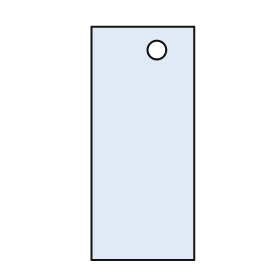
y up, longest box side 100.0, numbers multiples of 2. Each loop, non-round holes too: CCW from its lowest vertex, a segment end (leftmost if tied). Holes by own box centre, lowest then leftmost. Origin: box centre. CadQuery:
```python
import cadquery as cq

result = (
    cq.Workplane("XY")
    .moveTo(-22.0, -50.0)
    .lineTo(22.0, -50.0)
    .lineTo(22.0, 50.0)
    .lineTo(-22.0, 50.0)
    .close()
    .moveTo(6.0, 40.0)
    .circle(4.0)
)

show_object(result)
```